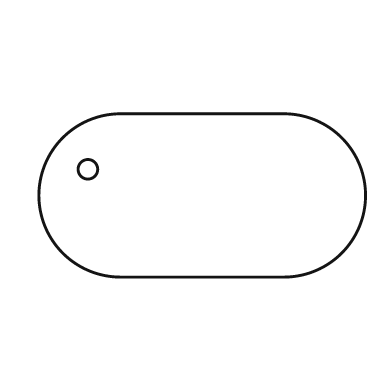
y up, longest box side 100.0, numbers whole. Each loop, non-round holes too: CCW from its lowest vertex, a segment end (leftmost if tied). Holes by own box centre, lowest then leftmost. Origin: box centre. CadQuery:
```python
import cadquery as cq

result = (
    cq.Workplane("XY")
    .moveTo(-25.0, -25.0)
    .lineTo(25.0, -25.0)
    .threePointArc((50.0, 0.0), (25.0, 25.0))
    .lineTo(-25.0, 25.0)
    .threePointArc((-50.0, 0.0), (-25.0, -25.0))
    .close()
    .moveTo(-35.0, 8.0)
    .circle(3.0)
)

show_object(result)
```